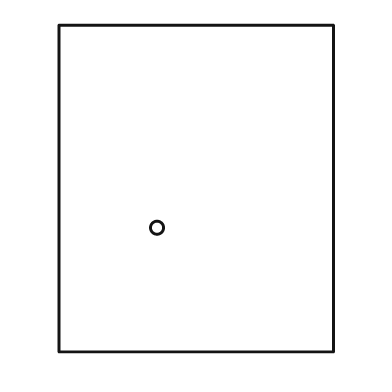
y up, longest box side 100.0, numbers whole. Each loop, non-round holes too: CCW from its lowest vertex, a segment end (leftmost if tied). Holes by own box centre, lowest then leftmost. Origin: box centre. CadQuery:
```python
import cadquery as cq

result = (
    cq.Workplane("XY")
    .moveTo(-42.0, -50.0)
    .lineTo(42.0, -50.0)
    .lineTo(42.0, 50.0)
    .lineTo(-42.0, 50.0)
    .close()
    .moveTo(-12.0, -12.0)
    .circle(2.0)
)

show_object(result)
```